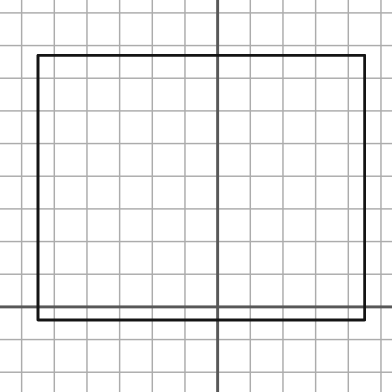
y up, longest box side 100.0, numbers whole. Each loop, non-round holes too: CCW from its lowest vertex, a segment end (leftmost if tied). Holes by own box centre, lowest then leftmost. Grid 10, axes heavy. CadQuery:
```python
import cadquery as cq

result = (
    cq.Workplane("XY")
    .moveTo(-55.0, -4.0)
    .lineTo(45.0, -4.0)
    .lineTo(45.0, 77.0)
    .lineTo(-55.0, 77.0)
    .close()
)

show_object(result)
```